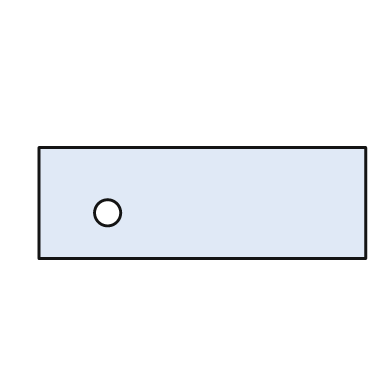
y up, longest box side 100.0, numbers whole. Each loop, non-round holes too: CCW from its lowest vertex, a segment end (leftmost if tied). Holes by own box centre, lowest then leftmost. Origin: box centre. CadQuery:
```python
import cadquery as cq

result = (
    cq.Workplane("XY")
    .moveTo(-50.0, -17.0)
    .lineTo(50.0, -17.0)
    .lineTo(50.0, 17.0)
    .lineTo(-50.0, 17.0)
    .close()
    .moveTo(-29.0, -3.0)
    .circle(4.0)
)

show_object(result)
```